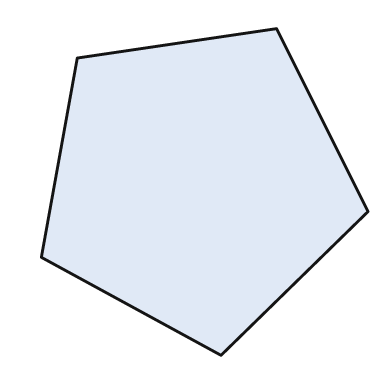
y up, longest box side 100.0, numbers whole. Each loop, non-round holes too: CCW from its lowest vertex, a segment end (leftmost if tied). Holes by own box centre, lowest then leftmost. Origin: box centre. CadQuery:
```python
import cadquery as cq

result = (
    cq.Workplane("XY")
    .moveTo(5.0, -50.0)
    .lineTo(50.0, -6.0)
    .lineTo(22.0, 50.0)
    .lineTo(-39.0, 41.0)
    .lineTo(-50.0, -20.0)
    .close()
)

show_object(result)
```